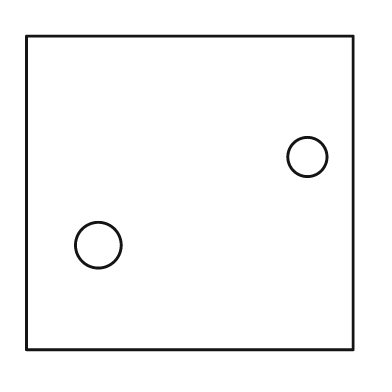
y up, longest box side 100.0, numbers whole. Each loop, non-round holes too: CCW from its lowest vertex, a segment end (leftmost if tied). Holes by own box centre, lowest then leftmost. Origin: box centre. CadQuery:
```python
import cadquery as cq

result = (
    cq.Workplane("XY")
    .moveTo(-50.0, -48.0)
    .lineTo(50.0, -48.0)
    .lineTo(50.0, 48.0)
    .lineTo(-50.0, 48.0)
    .close()
    .moveTo(-28.0, -16.0)
    .circle(7.0)
    .moveTo(36.0, 11.0)
    .circle(6.0)
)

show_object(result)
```